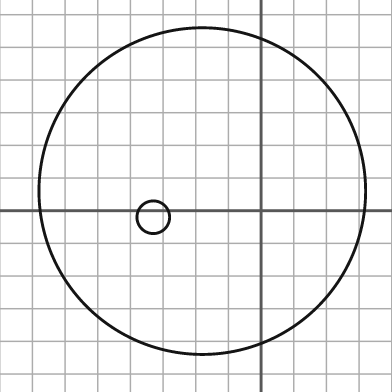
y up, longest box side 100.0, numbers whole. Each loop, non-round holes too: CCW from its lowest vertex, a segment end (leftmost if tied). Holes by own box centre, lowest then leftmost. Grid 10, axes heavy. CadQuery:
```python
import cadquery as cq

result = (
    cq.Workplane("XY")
    .moveTo(-18.0, 6.0)
    .circle(50.0)
    .moveTo(-33.0, -2.0)
    .circle(5.0)
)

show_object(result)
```